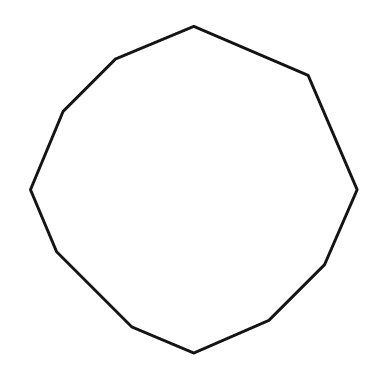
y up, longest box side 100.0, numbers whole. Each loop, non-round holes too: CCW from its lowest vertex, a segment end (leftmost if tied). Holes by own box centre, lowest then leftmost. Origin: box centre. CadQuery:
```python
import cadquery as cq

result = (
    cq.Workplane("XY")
    .moveTo(0.0, -50.0)
    .lineTo(23.0, -40.0)
    .lineTo(40.0, -23.0)
    .lineTo(50.0, 0.0)
    .lineTo(35.0, 35.0)
    .lineTo(0.0, 50.0)
    .lineTo(-24.0, 40.0)
    .lineTo(-40.0, 24.0)
    .lineTo(-50.0, 0.0)
    .lineTo(-42.0, -19.0)
    .lineTo(-19.0, -42.0)
    .close()
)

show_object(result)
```